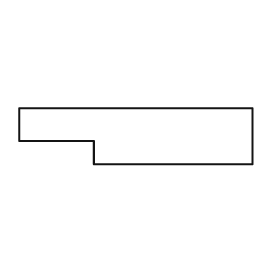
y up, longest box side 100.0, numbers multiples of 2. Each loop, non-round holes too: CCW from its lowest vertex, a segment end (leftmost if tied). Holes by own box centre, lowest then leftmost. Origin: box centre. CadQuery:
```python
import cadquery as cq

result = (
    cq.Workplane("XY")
    .moveTo(-18.0, -12.0)
    .lineTo(50.0, -12.0)
    .lineTo(50.0, 12.0)
    .lineTo(-50.0, 12.0)
    .lineTo(-50.0, -2.0)
    .lineTo(-18.0, -2.0)
    .close()
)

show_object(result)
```